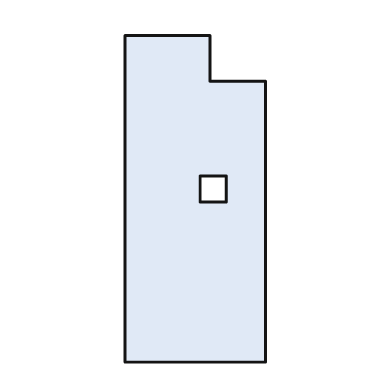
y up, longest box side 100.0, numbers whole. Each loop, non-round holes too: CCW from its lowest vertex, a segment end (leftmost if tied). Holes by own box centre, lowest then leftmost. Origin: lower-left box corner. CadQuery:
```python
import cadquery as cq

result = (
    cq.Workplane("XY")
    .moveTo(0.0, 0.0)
    .lineTo(43.0, 0.0)
    .lineTo(43.0, 86.0)
    .lineTo(26.0, 86.0)
    .lineTo(26.0, 100.0)
    .lineTo(0.0, 100.0)
    .close()
    .moveTo(23.0, 49.0)
    .lineTo(31.0, 49.0)
    .lineTo(31.0, 57.0)
    .lineTo(23.0, 57.0)
    .close()
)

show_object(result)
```